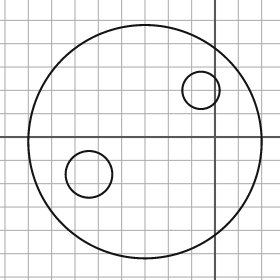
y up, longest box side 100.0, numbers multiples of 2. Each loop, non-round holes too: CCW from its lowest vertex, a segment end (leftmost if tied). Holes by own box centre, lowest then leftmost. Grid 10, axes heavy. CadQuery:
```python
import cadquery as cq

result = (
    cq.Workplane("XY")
    .moveTo(-30.0, -2.0)
    .circle(50.0)
    .moveTo(-54.0, -16.0)
    .circle(10.0)
    .moveTo(-6.0, 20.0)
    .circle(8.0)
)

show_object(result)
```